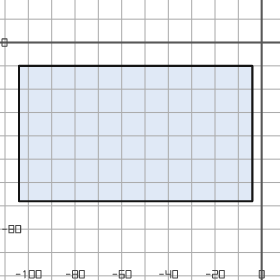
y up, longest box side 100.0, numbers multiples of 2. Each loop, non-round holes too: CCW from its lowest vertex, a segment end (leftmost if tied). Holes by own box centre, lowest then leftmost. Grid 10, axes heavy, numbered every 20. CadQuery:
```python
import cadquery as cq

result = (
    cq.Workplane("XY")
    .moveTo(-104.0, -68.0)
    .lineTo(-4.0, -68.0)
    .lineTo(-4.0, -10.0)
    .lineTo(-104.0, -10.0)
    .close()
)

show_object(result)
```